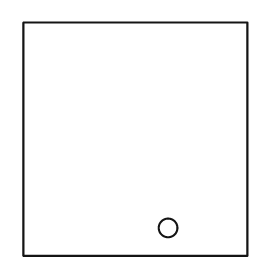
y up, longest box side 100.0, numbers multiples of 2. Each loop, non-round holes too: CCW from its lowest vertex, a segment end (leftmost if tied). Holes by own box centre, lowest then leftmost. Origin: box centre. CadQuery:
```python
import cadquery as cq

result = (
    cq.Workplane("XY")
    .moveTo(-48.0, -50.0)
    .lineTo(48.0, -50.0)
    .lineTo(48.0, 50.0)
    .lineTo(-48.0, 50.0)
    .close()
    .moveTo(14.0, -38.0)
    .circle(4.0)
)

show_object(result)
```